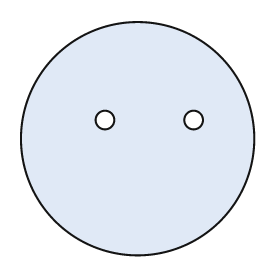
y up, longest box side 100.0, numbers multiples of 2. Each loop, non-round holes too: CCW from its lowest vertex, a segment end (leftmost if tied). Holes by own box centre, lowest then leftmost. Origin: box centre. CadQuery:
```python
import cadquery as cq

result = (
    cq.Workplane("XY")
    .moveTo(0.0, 0.0)
    .circle(50.0)
    .moveTo(-14.0, 8.0)
    .circle(4.0)
    .moveTo(24.0, 8.0)
    .circle(4.0)
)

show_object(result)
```